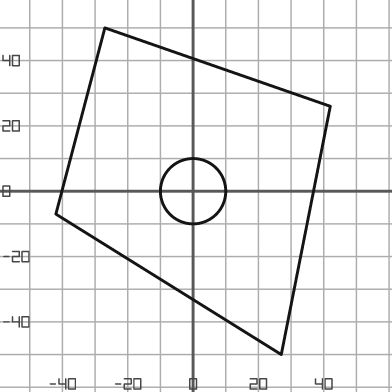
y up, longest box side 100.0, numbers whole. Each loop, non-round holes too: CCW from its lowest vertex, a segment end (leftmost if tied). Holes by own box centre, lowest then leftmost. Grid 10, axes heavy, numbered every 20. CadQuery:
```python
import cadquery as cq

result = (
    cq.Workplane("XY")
    .moveTo(27.0, -50.0)
    .lineTo(42.0, 26.0)
    .lineTo(-27.0, 50.0)
    .lineTo(-42.0, -7.0)
    .close()
    .moveTo(0.0, 0.0)
    .circle(10.0)
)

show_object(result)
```